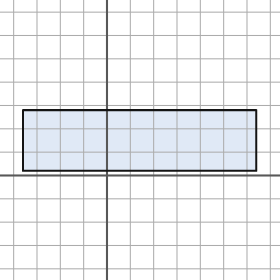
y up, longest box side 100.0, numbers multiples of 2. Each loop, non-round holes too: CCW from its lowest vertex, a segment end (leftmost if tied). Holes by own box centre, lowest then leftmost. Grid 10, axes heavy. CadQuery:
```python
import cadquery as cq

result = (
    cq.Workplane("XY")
    .moveTo(-36.0, 2.0)
    .lineTo(64.0, 2.0)
    .lineTo(64.0, 28.0)
    .lineTo(-36.0, 28.0)
    .close()
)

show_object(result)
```